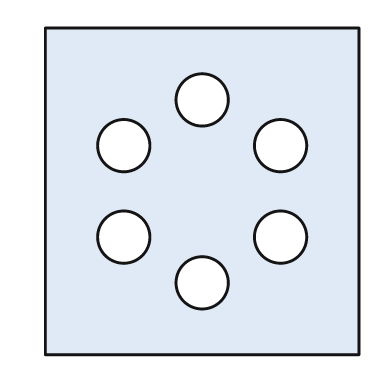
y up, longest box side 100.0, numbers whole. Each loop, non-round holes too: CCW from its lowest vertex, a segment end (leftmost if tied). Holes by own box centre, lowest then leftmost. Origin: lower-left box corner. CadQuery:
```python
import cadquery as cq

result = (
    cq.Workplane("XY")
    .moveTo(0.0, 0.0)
    .lineTo(96.0, 0.0)
    .lineTo(96.0, 100.0)
    .lineTo(0.0, 100.0)
    .close()
    .moveTo(48.0, 22.0)
    .circle(8.0)
    .moveTo(24.0, 36.0)
    .circle(8.0)
    .moveTo(72.0, 36.0)
    .circle(8.0)
    .moveTo(24.0, 64.0)
    .circle(8.0)
    .moveTo(72.0, 64.0)
    .circle(8.0)
    .moveTo(48.0, 78.0)
    .circle(8.0)
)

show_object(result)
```